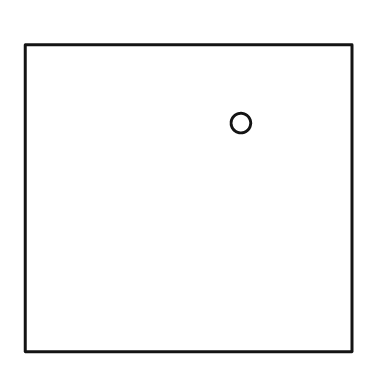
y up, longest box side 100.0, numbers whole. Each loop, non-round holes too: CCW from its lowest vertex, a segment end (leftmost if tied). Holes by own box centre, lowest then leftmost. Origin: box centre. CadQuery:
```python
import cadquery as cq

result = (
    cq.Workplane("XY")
    .moveTo(-50.0, -47.0)
    .lineTo(50.0, -47.0)
    .lineTo(50.0, 47.0)
    .lineTo(-50.0, 47.0)
    .close()
    .moveTo(16.0, 23.0)
    .circle(3.0)
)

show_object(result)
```